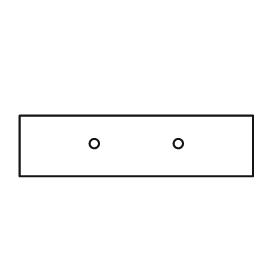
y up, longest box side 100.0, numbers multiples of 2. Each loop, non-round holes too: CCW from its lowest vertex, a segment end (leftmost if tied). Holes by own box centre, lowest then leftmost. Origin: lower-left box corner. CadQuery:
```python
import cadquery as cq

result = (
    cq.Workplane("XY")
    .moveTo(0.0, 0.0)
    .lineTo(100.0, 0.0)
    .lineTo(100.0, 26.0)
    .lineTo(0.0, 26.0)
    .close()
    .moveTo(32.0, 14.0)
    .circle(2.0)
    .moveTo(68.0, 14.0)
    .circle(2.0)
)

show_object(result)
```